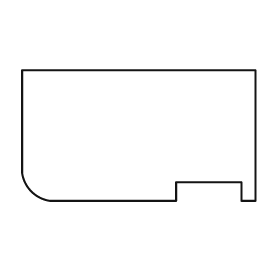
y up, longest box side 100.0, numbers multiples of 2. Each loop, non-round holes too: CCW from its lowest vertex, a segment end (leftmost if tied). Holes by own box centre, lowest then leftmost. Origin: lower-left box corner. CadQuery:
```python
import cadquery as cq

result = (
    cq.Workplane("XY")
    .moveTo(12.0, 0.0)
    .lineTo(66.0, 0.0)
    .lineTo(66.0, 8.0)
    .lineTo(94.0, 8.0)
    .lineTo(94.0, 0.0)
    .lineTo(100.0, 0.0)
    .lineTo(100.0, 56.0)
    .lineTo(0.0, 56.0)
    .lineTo(0.0, 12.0)
    .threePointArc((4.0, 4.0), (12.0, 0.0))
    .close()
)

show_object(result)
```